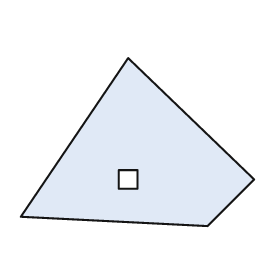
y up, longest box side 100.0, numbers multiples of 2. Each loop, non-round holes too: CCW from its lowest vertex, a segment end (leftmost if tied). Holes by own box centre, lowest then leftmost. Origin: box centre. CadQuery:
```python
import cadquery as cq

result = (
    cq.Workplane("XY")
    .moveTo(30.0, -36.0)
    .lineTo(50.0, -16.0)
    .lineTo(-4.0, 36.0)
    .lineTo(-50.0, -32.0)
    .close()
    .moveTo(-8.0, -20.0)
    .lineTo(0.0, -20.0)
    .lineTo(0.0, -12.0)
    .lineTo(-8.0, -12.0)
    .close()
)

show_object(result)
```